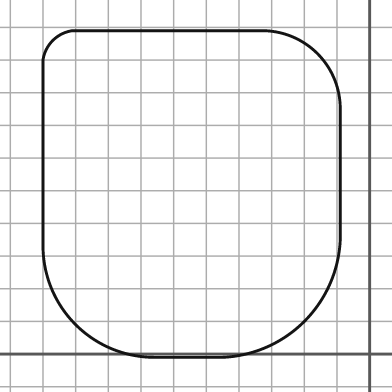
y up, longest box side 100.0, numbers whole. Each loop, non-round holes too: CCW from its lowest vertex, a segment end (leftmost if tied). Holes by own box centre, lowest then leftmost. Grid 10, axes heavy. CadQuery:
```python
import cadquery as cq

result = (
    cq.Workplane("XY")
    .moveTo(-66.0, -1.0)
    .lineTo(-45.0, -1.0)
    .threePointArc((-20.0, 10.0), (-9.0, 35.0))
    .lineTo(-9.0, 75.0)
    .threePointArc((-16.0, 92.0), (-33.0, 99.0))
    .lineTo(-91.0, 99.0)
    .threePointArc((-97.0, 96.0), (-100.0, 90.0))
    .lineTo(-100.0, 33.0)
    .threePointArc((-90.0, 9.0), (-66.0, -1.0))
    .close()
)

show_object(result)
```